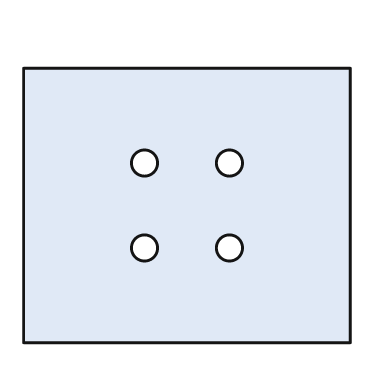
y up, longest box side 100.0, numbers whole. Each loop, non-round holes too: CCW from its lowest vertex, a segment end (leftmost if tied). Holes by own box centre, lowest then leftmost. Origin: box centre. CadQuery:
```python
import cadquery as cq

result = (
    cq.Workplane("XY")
    .moveTo(-50.0, -42.0)
    .lineTo(50.0, -42.0)
    .lineTo(50.0, 42.0)
    .lineTo(-50.0, 42.0)
    .close()
    .moveTo(-13.0, -13.0)
    .circle(4.0)
    .moveTo(13.0, -13.0)
    .circle(4.0)
    .moveTo(-13.0, 13.0)
    .circle(4.0)
    .moveTo(13.0, 13.0)
    .circle(4.0)
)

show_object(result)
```